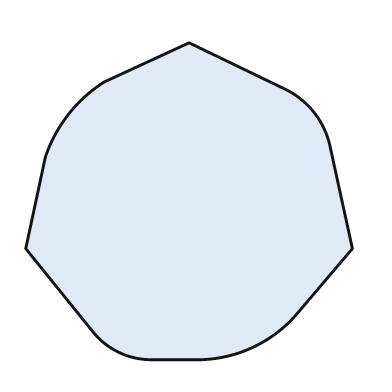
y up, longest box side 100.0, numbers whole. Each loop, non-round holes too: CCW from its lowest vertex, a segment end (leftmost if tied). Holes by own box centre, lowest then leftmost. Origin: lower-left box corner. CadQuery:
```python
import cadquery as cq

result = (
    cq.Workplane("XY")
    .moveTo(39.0, 0.0)
    .lineTo(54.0, 0.0)
    .threePointArc((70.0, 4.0), (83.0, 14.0))
    .lineTo(100.0, 34.0)
    .lineTo(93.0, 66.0)
    .threePointArc((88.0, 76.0), (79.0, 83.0))
    .lineTo(50.0, 97.0)
    .lineTo(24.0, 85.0)
    .threePointArc((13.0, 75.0), (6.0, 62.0))
    .lineTo(0.0, 34.0)
    .lineTo(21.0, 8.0)
    .threePointArc((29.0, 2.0), (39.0, 0.0))
    .close()
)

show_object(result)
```